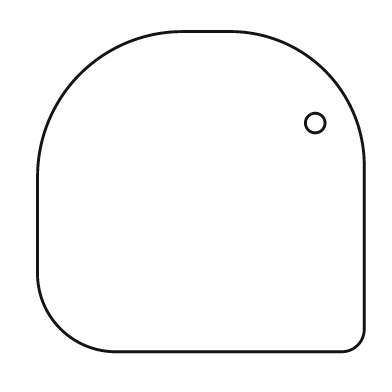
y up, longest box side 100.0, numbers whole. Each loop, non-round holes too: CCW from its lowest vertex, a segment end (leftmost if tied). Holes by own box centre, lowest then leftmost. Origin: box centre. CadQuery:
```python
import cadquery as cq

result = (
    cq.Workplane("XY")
    .moveTo(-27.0, -49.0)
    .lineTo(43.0, -49.0)
    .threePointArc((48.0, -47.0), (50.0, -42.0))
    .lineTo(50.0, 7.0)
    .threePointArc((38.0, 37.0), (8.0, 49.0))
    .lineTo(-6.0, 49.0)
    .threePointArc((-37.0, 36.0), (-50.0, 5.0))
    .lineTo(-50.0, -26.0)
    .threePointArc((-43.0, -42.0), (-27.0, -49.0))
    .close()
    .moveTo(35.0, 21.0)
    .circle(3.0)
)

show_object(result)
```